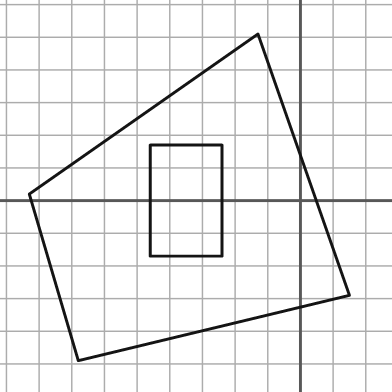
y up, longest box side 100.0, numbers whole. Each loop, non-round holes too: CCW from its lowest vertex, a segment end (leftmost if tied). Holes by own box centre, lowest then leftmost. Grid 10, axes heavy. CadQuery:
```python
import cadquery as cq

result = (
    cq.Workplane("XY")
    .moveTo(-68.0, -49.0)
    .lineTo(15.0, -29.0)
    .lineTo(-13.0, 51.0)
    .lineTo(-83.0, 2.0)
    .close()
    .moveTo(-46.0, -17.0)
    .lineTo(-24.0, -17.0)
    .lineTo(-24.0, 17.0)
    .lineTo(-46.0, 17.0)
    .close()
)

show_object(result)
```